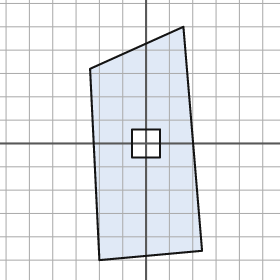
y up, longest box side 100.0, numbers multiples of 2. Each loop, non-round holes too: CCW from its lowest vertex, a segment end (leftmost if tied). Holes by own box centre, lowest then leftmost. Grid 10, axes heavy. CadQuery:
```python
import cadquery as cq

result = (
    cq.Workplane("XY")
    .moveTo(-20.0, -50.0)
    .lineTo(24.0, -46.0)
    .lineTo(16.0, 50.0)
    .lineTo(-24.0, 32.0)
    .close()
    .moveTo(-6.0, -6.0)
    .lineTo(6.0, -6.0)
    .lineTo(6.0, 6.0)
    .lineTo(-6.0, 6.0)
    .close()
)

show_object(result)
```